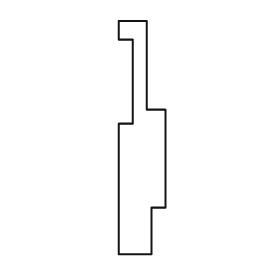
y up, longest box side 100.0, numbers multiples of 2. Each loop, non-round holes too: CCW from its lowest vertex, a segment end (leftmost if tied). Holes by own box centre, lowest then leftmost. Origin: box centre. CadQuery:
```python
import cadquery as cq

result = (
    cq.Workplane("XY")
    .moveTo(-10.0, -50.0)
    .lineTo(4.0, -50.0)
    .lineTo(4.0, -30.0)
    .lineTo(10.0, -30.0)
    .lineTo(10.0, 12.0)
    .lineTo(2.0, 12.0)
    .lineTo(2.0, 50.0)
    .lineTo(-10.0, 50.0)
    .lineTo(-10.0, 42.0)
    .lineTo(-4.0, 42.0)
    .lineTo(-4.0, 6.0)
    .lineTo(-10.0, 6.0)
    .close()
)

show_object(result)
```